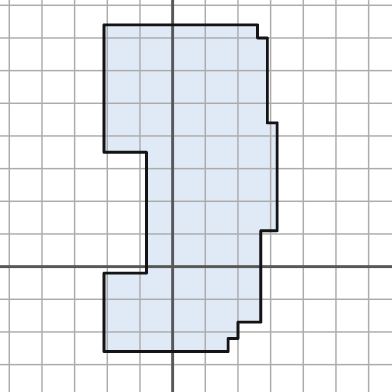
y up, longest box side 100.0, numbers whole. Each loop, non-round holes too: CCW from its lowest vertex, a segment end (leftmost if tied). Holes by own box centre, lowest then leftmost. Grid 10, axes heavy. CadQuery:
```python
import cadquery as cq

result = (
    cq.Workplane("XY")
    .moveTo(-21.0, -26.0)
    .lineTo(17.0, -26.0)
    .lineTo(17.0, -22.0)
    .lineTo(20.0, -22.0)
    .lineTo(20.0, -17.0)
    .lineTo(27.0, -17.0)
    .lineTo(27.0, 11.0)
    .lineTo(32.0, 11.0)
    .lineTo(32.0, 44.0)
    .lineTo(29.0, 44.0)
    .lineTo(29.0, 70.0)
    .lineTo(26.0, 70.0)
    .lineTo(26.0, 74.0)
    .lineTo(-21.0, 74.0)
    .lineTo(-21.0, 35.0)
    .lineTo(-8.0, 35.0)
    .lineTo(-8.0, -2.0)
    .lineTo(-21.0, -2.0)
    .close()
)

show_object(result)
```